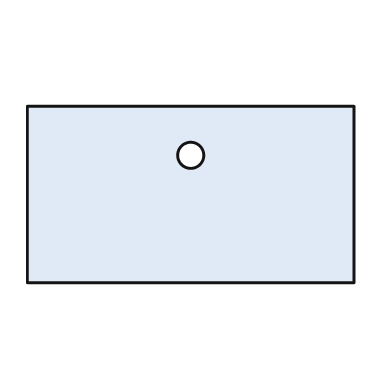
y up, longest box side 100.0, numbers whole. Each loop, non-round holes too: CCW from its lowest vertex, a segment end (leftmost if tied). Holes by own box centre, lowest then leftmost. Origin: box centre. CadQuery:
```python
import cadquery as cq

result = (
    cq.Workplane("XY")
    .moveTo(-50.0, -27.0)
    .lineTo(50.0, -27.0)
    .lineTo(50.0, 27.0)
    .lineTo(-50.0, 27.0)
    .close()
    .moveTo(0.0, 12.0)
    .circle(4.0)
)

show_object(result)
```